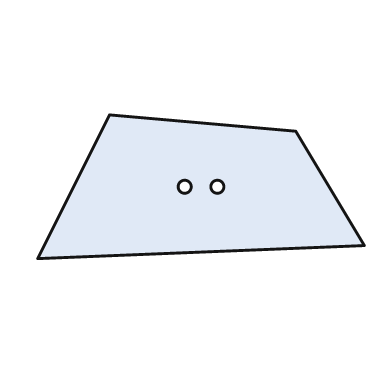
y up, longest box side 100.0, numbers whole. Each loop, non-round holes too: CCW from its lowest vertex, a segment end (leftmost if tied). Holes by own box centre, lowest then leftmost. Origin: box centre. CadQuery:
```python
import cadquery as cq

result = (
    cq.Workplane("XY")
    .moveTo(-50.0, -22.0)
    .lineTo(50.0, -18.0)
    .lineTo(29.0, 17.0)
    .lineTo(-28.0, 22.0)
    .close()
    .moveTo(-5.0, 0.0)
    .circle(2.0)
    .moveTo(5.0, 0.0)
    .circle(2.0)
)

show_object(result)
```